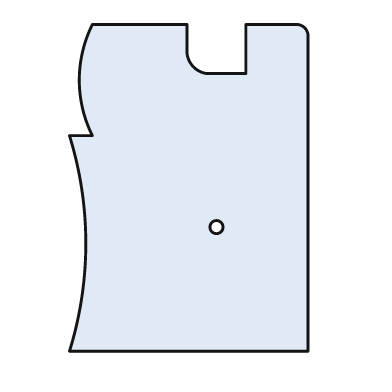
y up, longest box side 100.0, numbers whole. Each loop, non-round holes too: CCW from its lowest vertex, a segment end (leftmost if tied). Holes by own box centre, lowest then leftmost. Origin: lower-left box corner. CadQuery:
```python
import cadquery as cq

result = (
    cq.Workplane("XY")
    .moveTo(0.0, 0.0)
    .lineTo(73.0, 0.0)
    .lineTo(73.0, 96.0)
    .threePointArc((72.0, 99.0), (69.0, 100.0))
    .lineTo(54.0, 100.0)
    .lineTo(54.0, 85.0)
    .lineTo(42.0, 85.0)
    .threePointArc((38.0, 87.0), (36.0, 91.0))
    .lineTo(36.0, 100.0)
    .lineTo(7.0, 100.0)
    .threePointArc((3.0, 83.0), (7.0, 66.0))
    .lineTo(0.0, 66.0)
    .threePointArc((5.0, 33.0), (0.0, 0.0))
    .close()
    .moveTo(45.0, 38.0)
    .circle(2.0)
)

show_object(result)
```